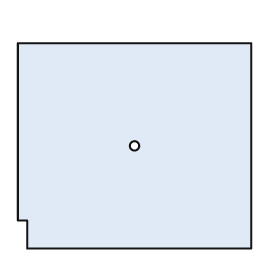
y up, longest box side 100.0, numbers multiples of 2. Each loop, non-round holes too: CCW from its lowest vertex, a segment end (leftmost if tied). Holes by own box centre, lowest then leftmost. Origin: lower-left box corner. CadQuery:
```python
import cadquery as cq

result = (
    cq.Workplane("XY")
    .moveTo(4.0, 0.0)
    .lineTo(100.0, 0.0)
    .lineTo(100.0, 88.0)
    .lineTo(0.0, 88.0)
    .lineTo(0.0, 12.0)
    .lineTo(4.0, 12.0)
    .close()
    .moveTo(50.0, 44.0)
    .circle(2.0)
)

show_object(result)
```